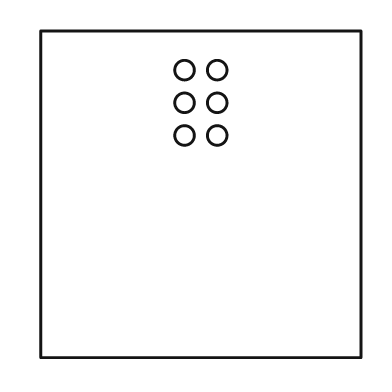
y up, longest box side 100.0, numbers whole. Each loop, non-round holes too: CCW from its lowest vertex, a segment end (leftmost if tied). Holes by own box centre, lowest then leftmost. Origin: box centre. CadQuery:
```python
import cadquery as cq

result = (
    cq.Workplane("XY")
    .moveTo(-49.0, -50.0)
    .lineTo(49.0, -50.0)
    .lineTo(49.0, 50.0)
    .lineTo(-49.0, 50.0)
    .close()
    .moveTo(-5.0, 18.0)
    .circle(3.0)
    .moveTo(5.0, 18.0)
    .circle(3.0)
    .moveTo(-5.0, 28.0)
    .circle(3.0)
    .moveTo(5.0, 28.0)
    .circle(3.0)
    .moveTo(-5.0, 38.0)
    .circle(3.0)
    .moveTo(5.0, 38.0)
    .circle(3.0)
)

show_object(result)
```